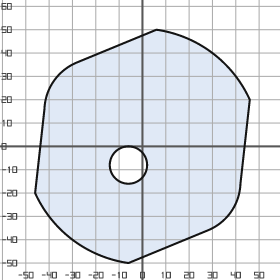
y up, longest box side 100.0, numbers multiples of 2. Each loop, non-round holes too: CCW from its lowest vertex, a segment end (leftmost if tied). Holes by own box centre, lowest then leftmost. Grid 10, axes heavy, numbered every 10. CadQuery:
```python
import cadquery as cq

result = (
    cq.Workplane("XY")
    .moveTo(-6.0, -50.0)
    .lineTo(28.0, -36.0)
    .threePointArc((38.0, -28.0), (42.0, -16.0))
    .lineTo(46.0, 20.0)
    .threePointArc((30.0, 40.0), (6.0, 50.0))
    .lineTo(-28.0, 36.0)
    .threePointArc((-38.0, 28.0), (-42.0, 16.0))
    .lineTo(-46.0, -20.0)
    .threePointArc((-30.0, -40.0), (-6.0, -50.0))
    .close()
    .moveTo(-6.0, -8.0)
    .circle(8.0)
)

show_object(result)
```